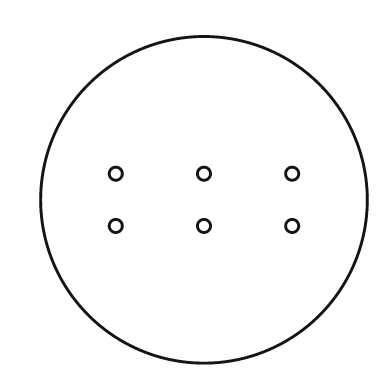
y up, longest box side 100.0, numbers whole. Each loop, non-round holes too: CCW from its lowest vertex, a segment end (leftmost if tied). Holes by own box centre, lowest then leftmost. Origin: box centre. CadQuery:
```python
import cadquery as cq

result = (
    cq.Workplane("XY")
    .moveTo(0.0, 0.0)
    .circle(50.0)
    .moveTo(-27.0, -8.0)
    .circle(2.0)
    .moveTo(0.0, -8.0)
    .circle(2.0)
    .moveTo(27.0, -8.0)
    .circle(2.0)
    .moveTo(-27.0, 8.0)
    .circle(2.0)
    .moveTo(0.0, 8.0)
    .circle(2.0)
    .moveTo(27.0, 8.0)
    .circle(2.0)
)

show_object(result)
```